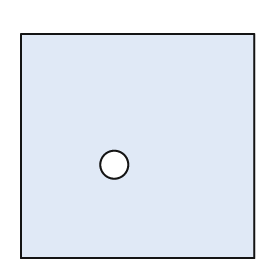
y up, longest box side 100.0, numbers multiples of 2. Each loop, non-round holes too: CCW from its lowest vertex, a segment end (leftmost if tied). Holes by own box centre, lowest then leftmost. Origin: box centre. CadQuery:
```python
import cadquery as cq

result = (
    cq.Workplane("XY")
    .moveTo(-50.0, -48.0)
    .lineTo(50.0, -48.0)
    .lineTo(50.0, 48.0)
    .lineTo(-50.0, 48.0)
    .close()
    .moveTo(-10.0, -8.0)
    .circle(6.0)
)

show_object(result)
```